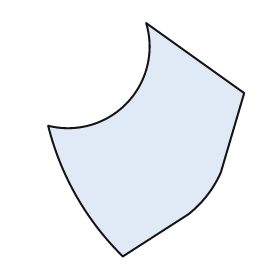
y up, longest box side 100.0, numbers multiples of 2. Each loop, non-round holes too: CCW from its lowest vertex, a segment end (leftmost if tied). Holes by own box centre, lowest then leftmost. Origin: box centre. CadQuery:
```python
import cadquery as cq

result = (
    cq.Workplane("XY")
    .moveTo(-10.0, -50.0)
    .lineTo(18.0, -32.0)
    .threePointArc((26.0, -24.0), (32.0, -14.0))
    .lineTo(42.0, 20.0)
    .lineTo(0.0, 50.0)
    .threePointArc((-8.0, 16.0), (-42.0, 6.0))
    .threePointArc((-30.0, -24.0), (-10.0, -50.0))
    .close()
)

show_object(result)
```